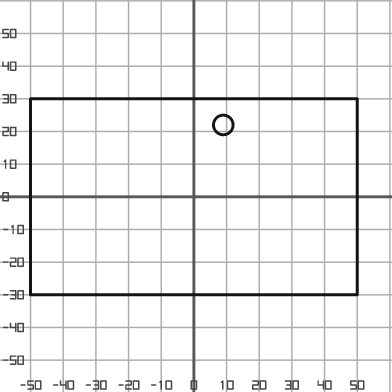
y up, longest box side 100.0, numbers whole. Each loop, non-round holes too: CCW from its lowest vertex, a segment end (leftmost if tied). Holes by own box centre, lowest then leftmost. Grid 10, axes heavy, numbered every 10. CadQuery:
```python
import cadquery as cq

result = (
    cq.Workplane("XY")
    .moveTo(-50.0, -30.0)
    .lineTo(50.0, -30.0)
    .lineTo(50.0, 30.0)
    .lineTo(-50.0, 30.0)
    .close()
    .moveTo(9.0, 22.0)
    .circle(3.0)
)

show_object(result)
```